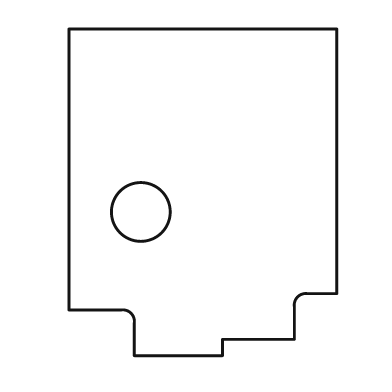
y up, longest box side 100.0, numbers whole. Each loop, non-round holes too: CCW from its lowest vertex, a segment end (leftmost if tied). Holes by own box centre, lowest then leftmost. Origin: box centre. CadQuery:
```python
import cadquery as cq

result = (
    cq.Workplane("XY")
    .moveTo(-21.0, -50.0)
    .lineTo(6.0, -50.0)
    .lineTo(6.0, -45.0)
    .lineTo(28.0, -45.0)
    .lineTo(28.0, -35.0)
    .threePointArc((29.0, -32.0), (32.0, -31.0))
    .lineTo(41.0, -31.0)
    .lineTo(41.0, 50.0)
    .lineTo(-41.0, 50.0)
    .lineTo(-41.0, -36.0)
    .lineTo(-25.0, -36.0)
    .threePointArc((-22.0, -37.0), (-21.0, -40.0))
    .close()
    .moveTo(-19.0, -6.0)
    .circle(9.0)
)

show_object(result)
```